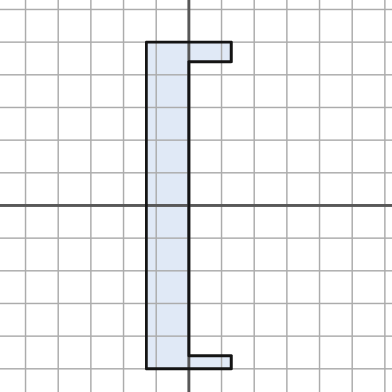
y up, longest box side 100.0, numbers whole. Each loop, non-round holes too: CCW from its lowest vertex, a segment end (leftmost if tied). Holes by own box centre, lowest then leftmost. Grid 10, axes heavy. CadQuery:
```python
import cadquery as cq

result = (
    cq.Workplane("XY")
    .moveTo(-13.0, -50.0)
    .lineTo(13.0, -50.0)
    .lineTo(13.0, -46.0)
    .lineTo(0.0, -46.0)
    .lineTo(0.0, 44.0)
    .lineTo(13.0, 44.0)
    .lineTo(13.0, 50.0)
    .lineTo(-13.0, 50.0)
    .close()
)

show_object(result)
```